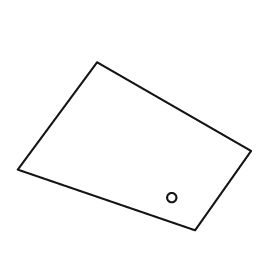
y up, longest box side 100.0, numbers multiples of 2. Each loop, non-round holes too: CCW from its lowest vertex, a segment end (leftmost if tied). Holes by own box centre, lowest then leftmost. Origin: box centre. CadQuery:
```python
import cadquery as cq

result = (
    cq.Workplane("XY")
    .moveTo(26.0, -36.0)
    .lineTo(50.0, -2.0)
    .lineTo(-16.0, 36.0)
    .lineTo(-50.0, -10.0)
    .close()
    .moveTo(16.0, -22.0)
    .circle(2.0)
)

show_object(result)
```